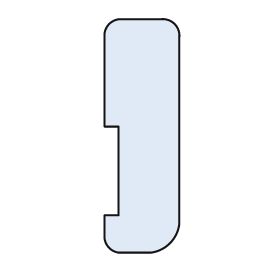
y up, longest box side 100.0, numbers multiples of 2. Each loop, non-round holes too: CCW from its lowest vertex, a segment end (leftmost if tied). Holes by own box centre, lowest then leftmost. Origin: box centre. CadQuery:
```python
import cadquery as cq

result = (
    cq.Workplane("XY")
    .moveTo(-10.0, -50.0)
    .lineTo(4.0, -50.0)
    .threePointArc((12.0, -46.0), (16.0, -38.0))
    .lineTo(16.0, 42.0)
    .threePointArc((14.0, 48.0), (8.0, 50.0))
    .lineTo(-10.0, 50.0)
    .threePointArc((-14.0, 48.0), (-16.0, 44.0))
    .lineTo(-16.0, 4.0)
    .lineTo(-10.0, 4.0)
    .lineTo(-10.0, -34.0)
    .lineTo(-16.0, -34.0)
    .lineTo(-16.0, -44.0)
    .threePointArc((-14.0, -48.0), (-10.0, -50.0))
    .close()
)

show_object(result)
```